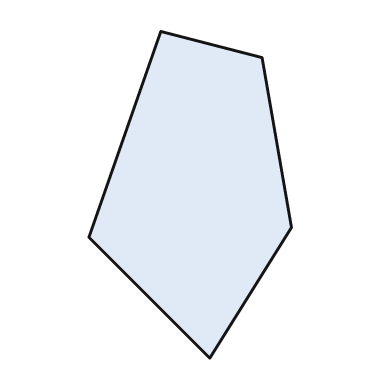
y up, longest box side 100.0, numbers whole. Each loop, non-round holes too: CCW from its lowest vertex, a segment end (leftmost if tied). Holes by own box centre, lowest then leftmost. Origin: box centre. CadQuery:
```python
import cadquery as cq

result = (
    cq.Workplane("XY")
    .moveTo(6.0, -50.0)
    .lineTo(31.0, -10.0)
    .lineTo(22.0, 42.0)
    .lineTo(-9.0, 50.0)
    .lineTo(-31.0, -13.0)
    .close()
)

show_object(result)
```